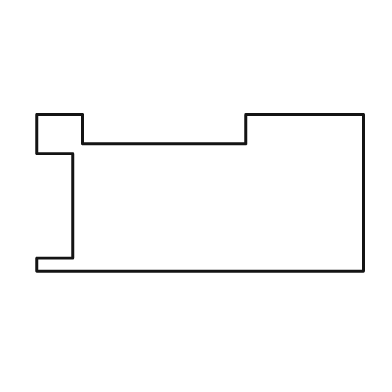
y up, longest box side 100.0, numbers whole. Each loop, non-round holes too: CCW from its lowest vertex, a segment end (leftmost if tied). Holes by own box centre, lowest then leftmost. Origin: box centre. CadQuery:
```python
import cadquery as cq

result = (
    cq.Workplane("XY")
    .moveTo(-50.0, -24.0)
    .lineTo(50.0, -24.0)
    .lineTo(50.0, 24.0)
    .lineTo(14.0, 24.0)
    .lineTo(14.0, 15.0)
    .lineTo(-36.0, 15.0)
    .lineTo(-36.0, 24.0)
    .lineTo(-50.0, 24.0)
    .lineTo(-50.0, 12.0)
    .lineTo(-39.0, 12.0)
    .lineTo(-39.0, -20.0)
    .lineTo(-50.0, -20.0)
    .close()
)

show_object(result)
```